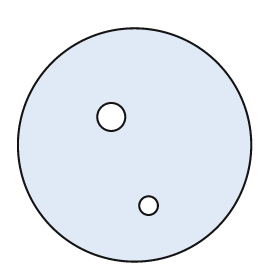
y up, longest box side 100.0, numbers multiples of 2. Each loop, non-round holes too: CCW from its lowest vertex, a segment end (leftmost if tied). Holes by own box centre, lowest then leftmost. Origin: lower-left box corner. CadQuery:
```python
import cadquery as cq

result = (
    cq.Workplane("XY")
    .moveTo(50.0, 50.0)
    .circle(50.0)
    .moveTo(56.0, 24.0)
    .circle(4.0)
    .moveTo(40.0, 62.0)
    .circle(6.0)
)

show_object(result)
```